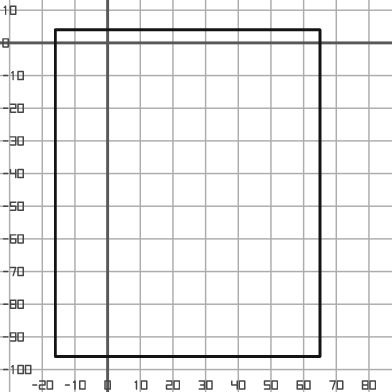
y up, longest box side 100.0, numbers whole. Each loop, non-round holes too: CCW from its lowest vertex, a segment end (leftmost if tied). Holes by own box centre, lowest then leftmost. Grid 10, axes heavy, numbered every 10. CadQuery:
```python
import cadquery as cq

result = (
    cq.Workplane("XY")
    .moveTo(-16.0, -96.0)
    .lineTo(65.0, -96.0)
    .lineTo(65.0, 4.0)
    .lineTo(-16.0, 4.0)
    .close()
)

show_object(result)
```